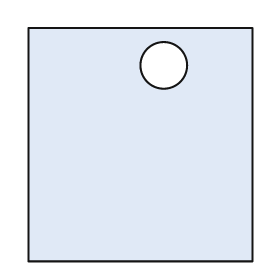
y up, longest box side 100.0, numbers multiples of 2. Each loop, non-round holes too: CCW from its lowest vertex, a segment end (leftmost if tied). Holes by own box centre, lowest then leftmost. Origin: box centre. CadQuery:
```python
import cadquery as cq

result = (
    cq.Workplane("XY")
    .moveTo(-48.0, -50.0)
    .lineTo(48.0, -50.0)
    .lineTo(48.0, 50.0)
    .lineTo(-48.0, 50.0)
    .close()
    .moveTo(10.0, 34.0)
    .circle(10.0)
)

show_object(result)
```